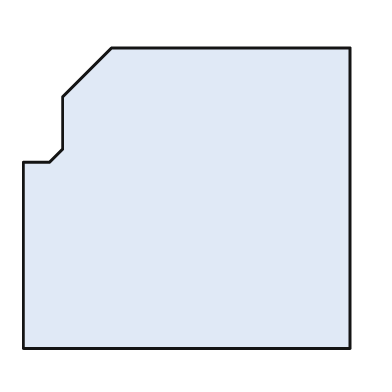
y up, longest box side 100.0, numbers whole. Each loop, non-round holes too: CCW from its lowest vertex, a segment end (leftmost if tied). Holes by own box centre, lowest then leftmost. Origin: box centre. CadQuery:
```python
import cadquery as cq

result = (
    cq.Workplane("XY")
    .moveTo(-50.0, -46.0)
    .lineTo(50.0, -46.0)
    .lineTo(50.0, 46.0)
    .lineTo(-23.0, 46.0)
    .lineTo(-38.0, 31.0)
    .lineTo(-38.0, 15.0)
    .lineTo(-42.0, 11.0)
    .lineTo(-50.0, 11.0)
    .close()
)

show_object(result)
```